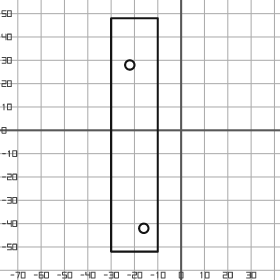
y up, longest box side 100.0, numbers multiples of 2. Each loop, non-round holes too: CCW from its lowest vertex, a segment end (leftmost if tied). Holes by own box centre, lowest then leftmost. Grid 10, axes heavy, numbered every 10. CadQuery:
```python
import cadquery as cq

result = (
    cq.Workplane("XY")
    .moveTo(-30.0, -52.0)
    .lineTo(-10.0, -52.0)
    .lineTo(-10.0, 48.0)
    .lineTo(-30.0, 48.0)
    .close()
    .moveTo(-16.0, -42.0)
    .circle(2.0)
    .moveTo(-22.0, 28.0)
    .circle(2.0)
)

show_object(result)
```